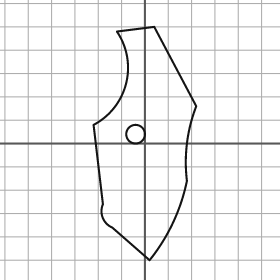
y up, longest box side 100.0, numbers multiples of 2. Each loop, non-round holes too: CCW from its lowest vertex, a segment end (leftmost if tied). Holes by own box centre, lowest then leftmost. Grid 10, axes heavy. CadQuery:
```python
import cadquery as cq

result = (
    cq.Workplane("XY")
    .moveTo(2.0, -50.0)
    .threePointArc((12.0, -34.0), (18.0, -16.0))
    .threePointArc((18.0, 0.0), (22.0, 16.0))
    .lineTo(4.0, 50.0)
    .lineTo(-12.0, 48.0)
    .threePointArc((-8.0, 26.0), (-22.0, 8.0))
    .lineTo(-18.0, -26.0)
    .threePointArc((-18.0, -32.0), (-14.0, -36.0))
    .close()
    .moveTo(-4.0, 4.0)
    .circle(4.0)
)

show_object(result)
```